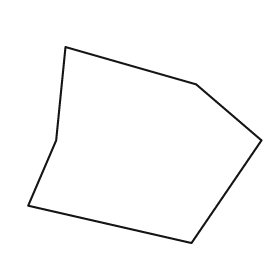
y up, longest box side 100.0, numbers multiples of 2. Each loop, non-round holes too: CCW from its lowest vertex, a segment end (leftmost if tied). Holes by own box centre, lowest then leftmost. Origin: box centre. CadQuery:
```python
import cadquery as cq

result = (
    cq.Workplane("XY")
    .moveTo(20.0, -42.0)
    .lineTo(50.0, 2.0)
    .lineTo(22.0, 26.0)
    .lineTo(-34.0, 42.0)
    .lineTo(-38.0, 2.0)
    .lineTo(-50.0, -26.0)
    .close()
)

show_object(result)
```